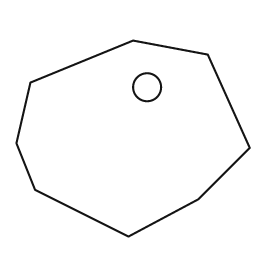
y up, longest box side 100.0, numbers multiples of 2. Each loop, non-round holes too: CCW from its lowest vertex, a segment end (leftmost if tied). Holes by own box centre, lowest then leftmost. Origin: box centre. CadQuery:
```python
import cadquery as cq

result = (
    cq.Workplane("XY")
    .moveTo(-2.0, -42.0)
    .lineTo(28.0, -26.0)
    .lineTo(50.0, -4.0)
    .lineTo(32.0, 36.0)
    .lineTo(0.0, 42.0)
    .lineTo(-44.0, 24.0)
    .lineTo(-50.0, -2.0)
    .lineTo(-42.0, -22.0)
    .close()
    .moveTo(6.0, 22.0)
    .circle(6.0)
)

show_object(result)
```